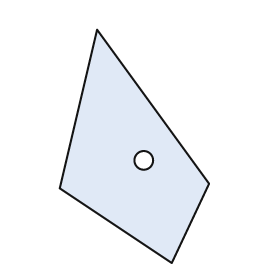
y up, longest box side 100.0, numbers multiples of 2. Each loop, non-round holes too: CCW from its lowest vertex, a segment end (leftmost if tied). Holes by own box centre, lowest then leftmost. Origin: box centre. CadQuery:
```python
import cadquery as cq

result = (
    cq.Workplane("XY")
    .moveTo(16.0, -50.0)
    .lineTo(32.0, -16.0)
    .lineTo(-16.0, 50.0)
    .lineTo(-32.0, -18.0)
    .close()
    .moveTo(4.0, -6.0)
    .circle(4.0)
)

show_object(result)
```